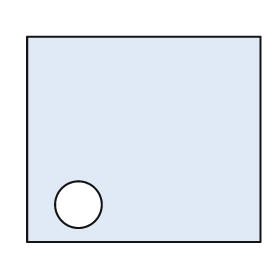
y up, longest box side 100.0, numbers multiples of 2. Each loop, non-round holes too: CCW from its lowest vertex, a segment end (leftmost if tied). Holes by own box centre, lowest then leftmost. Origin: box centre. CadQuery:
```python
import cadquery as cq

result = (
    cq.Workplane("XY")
    .moveTo(-50.0, -44.0)
    .lineTo(50.0, -44.0)
    .lineTo(50.0, 44.0)
    .lineTo(-50.0, 44.0)
    .close()
    .moveTo(-28.0, -28.0)
    .circle(10.0)
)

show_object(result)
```